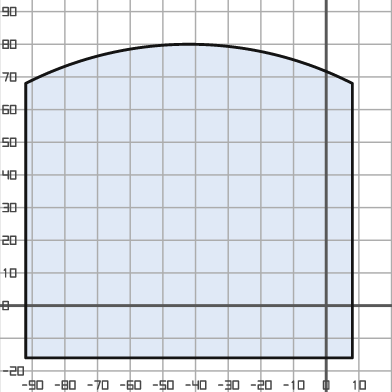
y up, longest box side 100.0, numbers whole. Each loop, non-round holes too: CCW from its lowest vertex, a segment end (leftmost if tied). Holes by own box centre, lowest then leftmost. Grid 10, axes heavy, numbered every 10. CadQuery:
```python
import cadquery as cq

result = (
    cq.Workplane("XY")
    .moveTo(-92.0, -16.0)
    .lineTo(8.0, -16.0)
    .lineTo(8.0, 68.0)
    .threePointArc((-42.0, 80.0), (-92.0, 68.0))
    .close()
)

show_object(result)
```